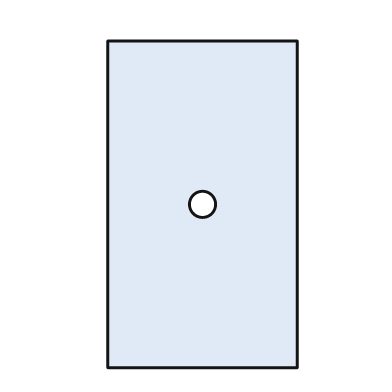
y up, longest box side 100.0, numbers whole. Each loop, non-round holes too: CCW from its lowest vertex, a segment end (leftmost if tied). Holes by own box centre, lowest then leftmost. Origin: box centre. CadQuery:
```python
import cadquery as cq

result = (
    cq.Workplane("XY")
    .moveTo(-29.0, -50.0)
    .lineTo(29.0, -50.0)
    .lineTo(29.0, 50.0)
    .lineTo(-29.0, 50.0)
    .close()
    .moveTo(0.0, 0.0)
    .circle(4.0)
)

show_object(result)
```